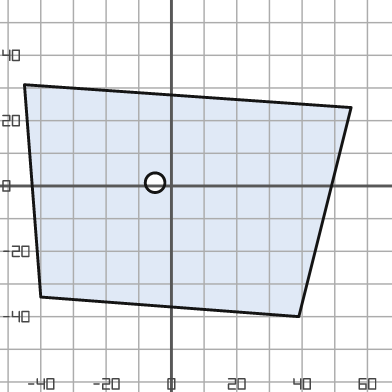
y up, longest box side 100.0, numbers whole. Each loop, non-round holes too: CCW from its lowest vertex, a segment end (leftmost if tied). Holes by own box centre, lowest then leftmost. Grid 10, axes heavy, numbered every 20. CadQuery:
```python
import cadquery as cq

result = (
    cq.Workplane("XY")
    .moveTo(39.0, -40.0)
    .lineTo(55.0, 24.0)
    .lineTo(-45.0, 31.0)
    .lineTo(-40.0, -34.0)
    .close()
    .moveTo(-5.0, 1.0)
    .circle(3.0)
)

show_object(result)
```